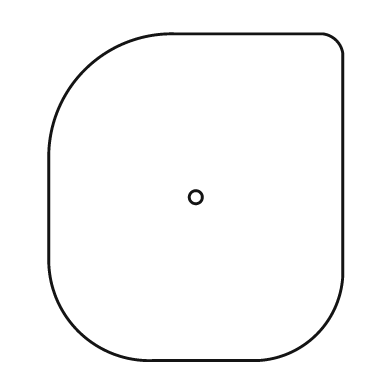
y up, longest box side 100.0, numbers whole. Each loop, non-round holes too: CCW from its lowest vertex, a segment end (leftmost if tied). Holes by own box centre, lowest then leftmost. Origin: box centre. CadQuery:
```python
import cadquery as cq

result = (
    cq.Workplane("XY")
    .moveTo(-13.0, -50.0)
    .lineTo(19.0, -50.0)
    .threePointArc((37.0, -42.0), (45.0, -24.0))
    .lineTo(45.0, 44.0)
    .threePointArc((43.0, 48.0), (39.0, 50.0))
    .lineTo(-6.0, 50.0)
    .threePointArc((-34.0, 39.0), (-45.0, 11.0))
    .lineTo(-45.0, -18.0)
    .threePointArc((-36.0, -41.0), (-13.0, -50.0))
    .close()
    .moveTo(0.0, 0.0)
    .circle(2.0)
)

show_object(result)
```